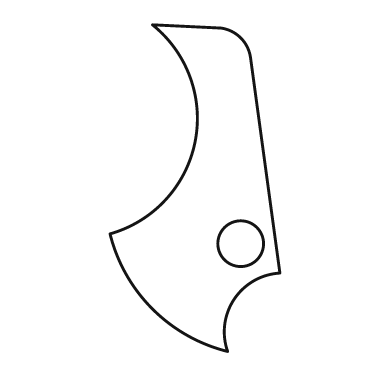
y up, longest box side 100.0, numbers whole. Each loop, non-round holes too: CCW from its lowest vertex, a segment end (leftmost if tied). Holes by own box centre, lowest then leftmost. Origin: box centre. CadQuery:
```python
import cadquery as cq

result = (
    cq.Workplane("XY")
    .moveTo(10.0, -50.0)
    .threePointArc((12.0, -34.0), (26.0, -26.0))
    .lineTo(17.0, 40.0)
    .threePointArc((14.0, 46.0), (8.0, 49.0))
    .lineTo(-13.0, 50.0)
    .threePointArc((0.0, 14.0), (-26.0, -14.0))
    .threePointArc((-13.0, -37.0), (10.0, -50.0))
    .close()
    .moveTo(14.0, -17.0)
    .circle(7.0)
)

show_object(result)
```